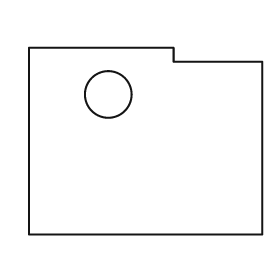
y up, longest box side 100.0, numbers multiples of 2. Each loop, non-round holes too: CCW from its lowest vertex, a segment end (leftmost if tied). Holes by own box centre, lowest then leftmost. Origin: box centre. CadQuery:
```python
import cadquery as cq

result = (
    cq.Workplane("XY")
    .moveTo(-50.0, -40.0)
    .lineTo(50.0, -40.0)
    .lineTo(50.0, 34.0)
    .lineTo(12.0, 34.0)
    .lineTo(12.0, 40.0)
    .lineTo(-50.0, 40.0)
    .close()
    .moveTo(-16.0, 20.0)
    .circle(10.0)
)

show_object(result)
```